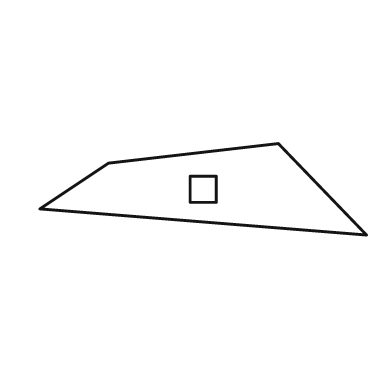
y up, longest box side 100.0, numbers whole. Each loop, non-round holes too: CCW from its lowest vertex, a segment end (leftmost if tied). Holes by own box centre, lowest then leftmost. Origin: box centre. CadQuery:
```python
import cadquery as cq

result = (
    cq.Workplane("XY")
    .moveTo(50.0, -14.0)
    .lineTo(23.0, 14.0)
    .lineTo(-29.0, 8.0)
    .lineTo(-50.0, -6.0)
    .close()
    .moveTo(-4.0, -4.0)
    .lineTo(4.0, -4.0)
    .lineTo(4.0, 4.0)
    .lineTo(-4.0, 4.0)
    .close()
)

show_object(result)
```